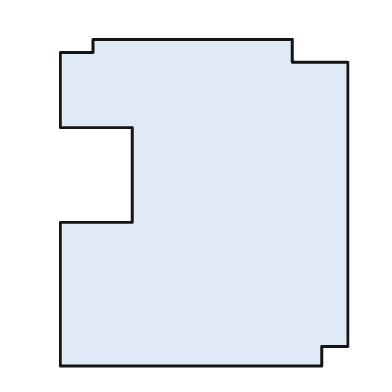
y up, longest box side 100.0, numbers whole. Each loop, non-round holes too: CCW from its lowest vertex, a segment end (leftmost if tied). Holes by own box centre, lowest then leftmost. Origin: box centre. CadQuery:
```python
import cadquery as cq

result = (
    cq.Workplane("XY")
    .moveTo(-44.0, -50.0)
    .lineTo(36.0, -50.0)
    .lineTo(36.0, -44.0)
    .lineTo(44.0, -44.0)
    .lineTo(44.0, 43.0)
    .lineTo(27.0, 43.0)
    .lineTo(27.0, 50.0)
    .lineTo(-34.0, 50.0)
    .lineTo(-34.0, 46.0)
    .lineTo(-44.0, 46.0)
    .lineTo(-44.0, 23.0)
    .lineTo(-22.0, 23.0)
    .lineTo(-22.0, -6.0)
    .lineTo(-44.0, -6.0)
    .close()
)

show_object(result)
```